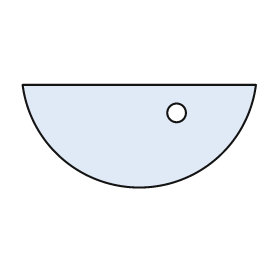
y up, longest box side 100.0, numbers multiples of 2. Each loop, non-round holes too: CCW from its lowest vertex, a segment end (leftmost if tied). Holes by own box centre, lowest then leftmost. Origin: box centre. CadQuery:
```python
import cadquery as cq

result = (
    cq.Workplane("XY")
    .moveTo(-50.0, 22.0)
    .threePointArc((0.0, -22.0), (50.0, 22.0))
    .close()
    .moveTo(16.0, 10.0)
    .circle(4.0)
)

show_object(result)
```